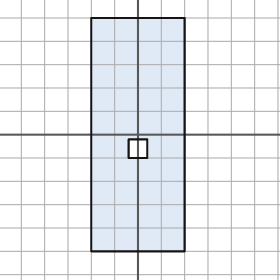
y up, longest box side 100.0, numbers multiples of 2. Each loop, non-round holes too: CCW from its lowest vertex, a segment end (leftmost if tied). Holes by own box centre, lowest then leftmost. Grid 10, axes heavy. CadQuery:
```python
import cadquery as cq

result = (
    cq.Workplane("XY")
    .moveTo(-20.0, -50.0)
    .lineTo(20.0, -50.0)
    .lineTo(20.0, 50.0)
    .lineTo(-20.0, 50.0)
    .close()
    .moveTo(-4.0, -10.0)
    .lineTo(4.0, -10.0)
    .lineTo(4.0, -2.0)
    .lineTo(-4.0, -2.0)
    .close()
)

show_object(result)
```